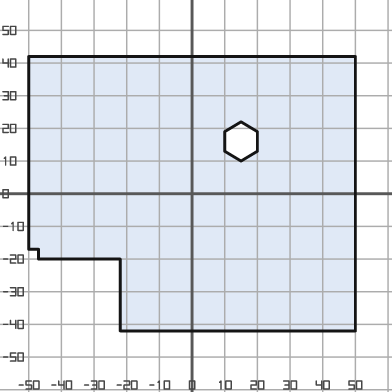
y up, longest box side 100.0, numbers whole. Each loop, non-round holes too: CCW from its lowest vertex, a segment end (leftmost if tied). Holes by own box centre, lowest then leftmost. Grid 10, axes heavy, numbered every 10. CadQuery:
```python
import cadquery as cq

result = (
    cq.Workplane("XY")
    .moveTo(-22.0, -42.0)
    .lineTo(50.0, -42.0)
    .lineTo(50.0, 42.0)
    .lineTo(-50.0, 42.0)
    .lineTo(-50.0, -17.0)
    .lineTo(-47.0, -17.0)
    .lineTo(-47.0, -20.0)
    .lineTo(-22.0, -20.0)
    .close()
    .moveTo(15.0, 10.0)
    .lineTo(20.0, 13.0)
    .lineTo(20.0, 19.0)
    .lineTo(15.0, 22.0)
    .lineTo(10.0, 19.0)
    .lineTo(10.0, 13.0)
    .close()
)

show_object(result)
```